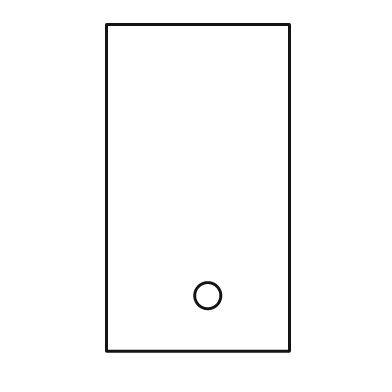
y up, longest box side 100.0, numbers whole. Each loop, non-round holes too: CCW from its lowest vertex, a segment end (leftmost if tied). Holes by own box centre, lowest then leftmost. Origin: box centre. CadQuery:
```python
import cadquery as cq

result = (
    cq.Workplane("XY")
    .moveTo(-28.0, -50.0)
    .lineTo(28.0, -50.0)
    .lineTo(28.0, 50.0)
    .lineTo(-28.0, 50.0)
    .close()
    .moveTo(3.0, -33.0)
    .circle(4.0)
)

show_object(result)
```